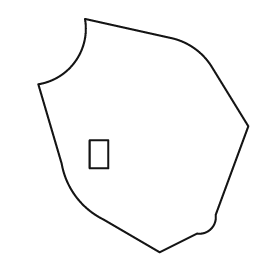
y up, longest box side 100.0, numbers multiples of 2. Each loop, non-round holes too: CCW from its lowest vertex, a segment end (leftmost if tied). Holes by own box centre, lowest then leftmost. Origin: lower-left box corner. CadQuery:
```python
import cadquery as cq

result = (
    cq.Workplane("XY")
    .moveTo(52.0, 0.0)
    .lineTo(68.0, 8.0)
    .threePointArc((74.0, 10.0), (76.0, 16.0))
    .lineTo(90.0, 54.0)
    .lineTo(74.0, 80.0)
    .threePointArc((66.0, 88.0), (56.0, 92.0))
    .lineTo(20.0, 100.0)
    .threePointArc((16.0, 82.0), (0.0, 72.0))
    .lineTo(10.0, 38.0)
    .threePointArc((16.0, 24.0), (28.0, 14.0))
    .close()
    .moveTo(22.0, 36.0)
    .lineTo(30.0, 36.0)
    .lineTo(30.0, 48.0)
    .lineTo(22.0, 48.0)
    .close()
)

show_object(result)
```